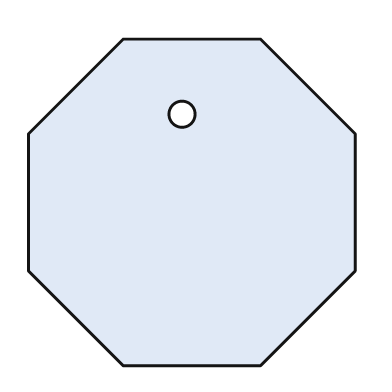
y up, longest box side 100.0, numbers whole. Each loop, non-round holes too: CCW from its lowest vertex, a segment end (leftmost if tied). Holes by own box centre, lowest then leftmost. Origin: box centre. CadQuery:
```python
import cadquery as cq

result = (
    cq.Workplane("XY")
    .moveTo(-21.0, -50.0)
    .lineTo(21.0, -50.0)
    .lineTo(50.0, -21.0)
    .lineTo(50.0, 21.0)
    .lineTo(21.0, 50.0)
    .lineTo(-21.0, 50.0)
    .lineTo(-50.0, 21.0)
    .lineTo(-50.0, -21.0)
    .close()
    .moveTo(-3.0, 27.0)
    .circle(4.0)
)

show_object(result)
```